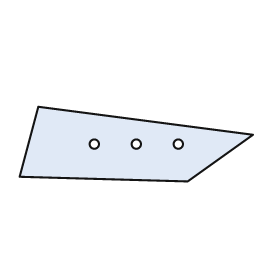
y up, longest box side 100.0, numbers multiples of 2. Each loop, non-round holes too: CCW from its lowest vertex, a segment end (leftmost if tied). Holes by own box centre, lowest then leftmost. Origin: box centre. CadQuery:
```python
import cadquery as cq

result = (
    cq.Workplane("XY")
    .moveTo(22.0, -16.0)
    .lineTo(50.0, 4.0)
    .lineTo(-42.0, 16.0)
    .lineTo(-50.0, -14.0)
    .close()
    .moveTo(-18.0, 0.0)
    .circle(2.0)
    .moveTo(0.0, 0.0)
    .circle(2.0)
    .moveTo(18.0, 0.0)
    .circle(2.0)
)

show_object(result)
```